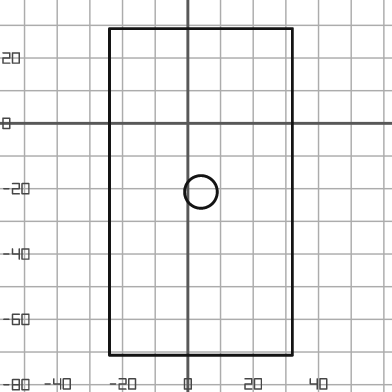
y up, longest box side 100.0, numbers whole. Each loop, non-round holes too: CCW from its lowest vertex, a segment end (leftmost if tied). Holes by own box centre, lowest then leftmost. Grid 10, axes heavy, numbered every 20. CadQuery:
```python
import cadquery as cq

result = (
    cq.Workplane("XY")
    .moveTo(-24.0, -71.0)
    .lineTo(32.0, -71.0)
    .lineTo(32.0, 29.0)
    .lineTo(-24.0, 29.0)
    .close()
    .moveTo(4.0, -21.0)
    .circle(5.0)
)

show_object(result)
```